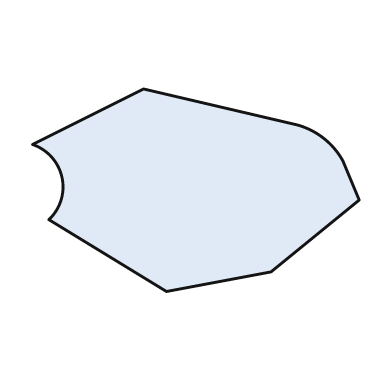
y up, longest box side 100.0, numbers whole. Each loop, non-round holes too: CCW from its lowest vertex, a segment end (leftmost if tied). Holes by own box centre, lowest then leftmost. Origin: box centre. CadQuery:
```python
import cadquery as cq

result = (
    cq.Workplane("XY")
    .moveTo(-9.0, -31.0)
    .lineTo(23.0, -25.0)
    .lineTo(50.0, -3.0)
    .lineTo(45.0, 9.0)
    .threePointArc((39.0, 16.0), (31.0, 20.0))
    .lineTo(-16.0, 31.0)
    .lineTo(-50.0, 14.0)
    .threePointArc((-41.0, 4.0), (-45.0, -9.0))
    .close()
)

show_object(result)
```